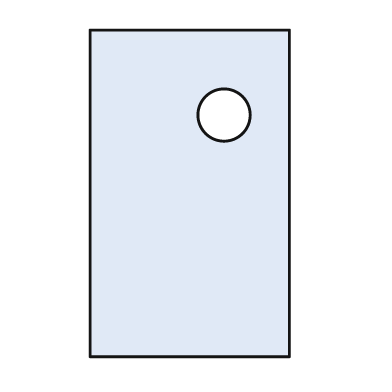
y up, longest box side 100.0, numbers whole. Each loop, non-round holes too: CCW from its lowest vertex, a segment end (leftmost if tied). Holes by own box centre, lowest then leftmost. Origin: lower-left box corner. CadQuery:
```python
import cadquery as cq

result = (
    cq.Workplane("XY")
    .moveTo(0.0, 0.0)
    .lineTo(61.0, 0.0)
    .lineTo(61.0, 100.0)
    .lineTo(0.0, 100.0)
    .close()
    .moveTo(41.0, 74.0)
    .circle(8.0)
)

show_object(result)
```